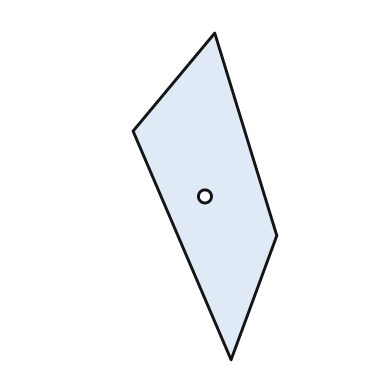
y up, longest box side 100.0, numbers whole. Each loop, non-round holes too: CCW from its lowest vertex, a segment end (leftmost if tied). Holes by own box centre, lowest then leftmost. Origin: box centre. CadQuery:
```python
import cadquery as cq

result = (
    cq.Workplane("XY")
    .moveTo(8.0, -50.0)
    .lineTo(22.0, -12.0)
    .lineTo(3.0, 50.0)
    .lineTo(-22.0, 20.0)
    .close()
    .moveTo(0.0, 0.0)
    .circle(2.0)
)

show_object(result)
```